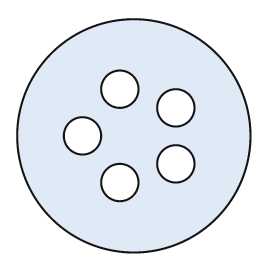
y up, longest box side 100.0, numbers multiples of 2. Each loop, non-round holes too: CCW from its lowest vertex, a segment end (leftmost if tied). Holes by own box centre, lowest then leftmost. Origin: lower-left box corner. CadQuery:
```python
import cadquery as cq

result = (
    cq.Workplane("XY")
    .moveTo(50.0, 50.0)
    .circle(50.0)
    .moveTo(44.0, 30.0)
    .circle(8.0)
    .moveTo(68.0, 38.0)
    .circle(8.0)
    .moveTo(28.0, 50.0)
    .circle(8.0)
    .moveTo(68.0, 62.0)
    .circle(8.0)
    .moveTo(44.0, 70.0)
    .circle(8.0)
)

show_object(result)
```